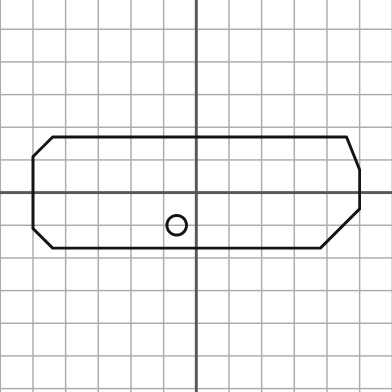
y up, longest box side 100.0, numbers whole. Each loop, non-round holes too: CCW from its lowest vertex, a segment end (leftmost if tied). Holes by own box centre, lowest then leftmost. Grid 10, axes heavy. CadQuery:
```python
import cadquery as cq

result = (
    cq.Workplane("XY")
    .moveTo(-44.0, -17.0)
    .lineTo(38.0, -17.0)
    .lineTo(50.0, -5.0)
    .lineTo(50.0, 7.0)
    .lineTo(46.0, 17.0)
    .lineTo(-44.0, 17.0)
    .lineTo(-50.0, 11.0)
    .lineTo(-50.0, -11.0)
    .close()
    .moveTo(-6.0, -10.0)
    .circle(3.0)
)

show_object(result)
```